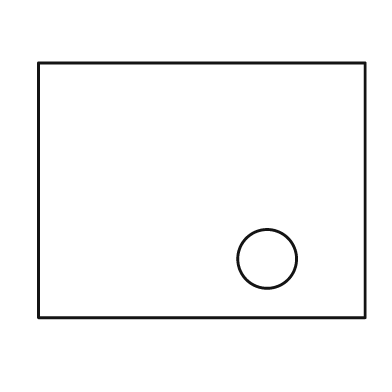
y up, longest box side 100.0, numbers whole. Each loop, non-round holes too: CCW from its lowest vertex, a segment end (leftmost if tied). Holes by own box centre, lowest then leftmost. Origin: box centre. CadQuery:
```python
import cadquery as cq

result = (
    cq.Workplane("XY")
    .moveTo(-50.0, -39.0)
    .lineTo(50.0, -39.0)
    .lineTo(50.0, 39.0)
    .lineTo(-50.0, 39.0)
    .close()
    .moveTo(20.0, -21.0)
    .circle(9.0)
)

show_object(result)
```